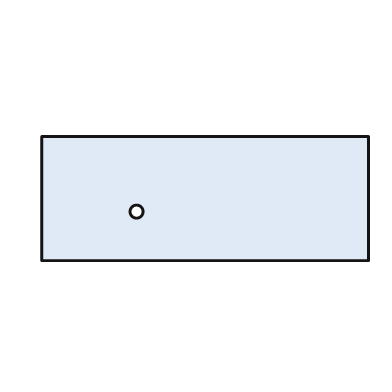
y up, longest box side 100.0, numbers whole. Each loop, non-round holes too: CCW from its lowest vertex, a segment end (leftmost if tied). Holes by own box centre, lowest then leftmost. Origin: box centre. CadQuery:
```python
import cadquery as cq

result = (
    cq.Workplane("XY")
    .moveTo(-50.0, -19.0)
    .lineTo(50.0, -19.0)
    .lineTo(50.0, 19.0)
    .lineTo(-50.0, 19.0)
    .close()
    .moveTo(-21.0, -4.0)
    .circle(2.0)
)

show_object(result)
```